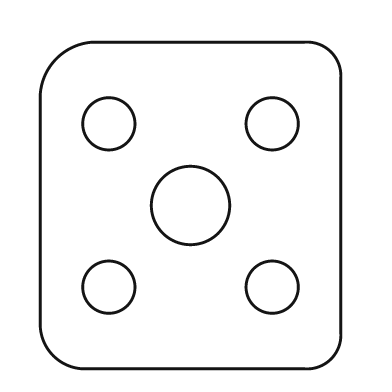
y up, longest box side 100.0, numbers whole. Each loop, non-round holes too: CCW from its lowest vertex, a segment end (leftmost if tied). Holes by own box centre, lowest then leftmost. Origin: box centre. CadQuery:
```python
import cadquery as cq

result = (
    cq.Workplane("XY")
    .moveTo(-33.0, -50.0)
    .lineTo(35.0, -50.0)
    .threePointArc((43.0, -47.0), (46.0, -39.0))
    .lineTo(46.0, 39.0)
    .threePointArc((43.0, 47.0), (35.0, 50.0))
    .lineTo(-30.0, 50.0)
    .threePointArc((-41.0, 45.0), (-46.0, 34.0))
    .lineTo(-46.0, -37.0)
    .threePointArc((-42.0, -46.0), (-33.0, -50.0))
    .close()
    .moveTo(-25.0, -25.0)
    .circle(8.0)
    .moveTo(25.0, -25.0)
    .circle(8.0)
    .moveTo(0.0, 0.0)
    .circle(12.0)
    .moveTo(-25.0, 25.0)
    .circle(8.0)
    .moveTo(25.0, 25.0)
    .circle(8.0)
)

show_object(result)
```